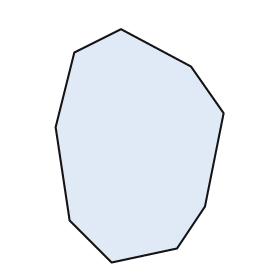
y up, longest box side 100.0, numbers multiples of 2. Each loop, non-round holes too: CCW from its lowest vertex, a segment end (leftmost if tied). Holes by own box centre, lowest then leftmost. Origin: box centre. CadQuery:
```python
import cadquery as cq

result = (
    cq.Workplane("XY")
    .moveTo(-12.0, -50.0)
    .lineTo(16.0, -44.0)
    .lineTo(28.0, -26.0)
    .lineTo(36.0, 14.0)
    .lineTo(22.0, 34.0)
    .lineTo(-8.0, 50.0)
    .lineTo(-28.0, 40.0)
    .lineTo(-36.0, 8.0)
    .lineTo(-30.0, -32.0)
    .close()
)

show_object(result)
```